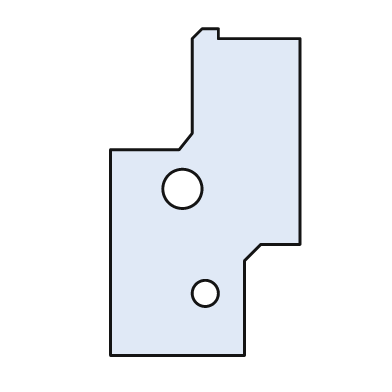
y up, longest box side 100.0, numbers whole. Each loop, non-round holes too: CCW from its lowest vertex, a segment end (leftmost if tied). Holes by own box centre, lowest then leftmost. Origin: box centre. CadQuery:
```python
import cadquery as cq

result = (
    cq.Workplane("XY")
    .moveTo(-29.0, -50.0)
    .lineTo(12.0, -50.0)
    .lineTo(12.0, -21.0)
    .lineTo(17.0, -16.0)
    .lineTo(29.0, -16.0)
    .lineTo(29.0, 47.0)
    .lineTo(4.0, 47.0)
    .lineTo(4.0, 50.0)
    .lineTo(-1.0, 50.0)
    .lineTo(-4.0, 47.0)
    .lineTo(-4.0, 18.0)
    .lineTo(-8.0, 13.0)
    .lineTo(-29.0, 13.0)
    .close()
    .moveTo(0.0, -31.0)
    .circle(4.0)
    .moveTo(-7.0, 1.0)
    .circle(6.0)
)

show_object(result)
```